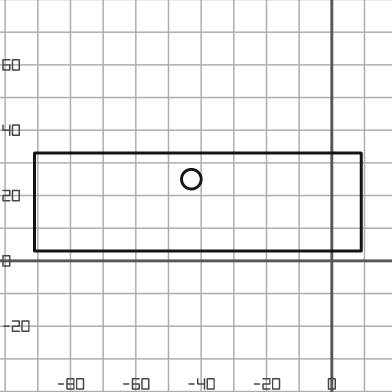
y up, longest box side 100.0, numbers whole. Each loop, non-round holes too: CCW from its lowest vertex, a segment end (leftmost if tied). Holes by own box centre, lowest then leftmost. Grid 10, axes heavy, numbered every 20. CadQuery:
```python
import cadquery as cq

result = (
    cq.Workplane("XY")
    .moveTo(-91.0, 3.0)
    .lineTo(9.0, 3.0)
    .lineTo(9.0, 33.0)
    .lineTo(-91.0, 33.0)
    .close()
    .moveTo(-43.0, 25.0)
    .circle(3.0)
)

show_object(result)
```